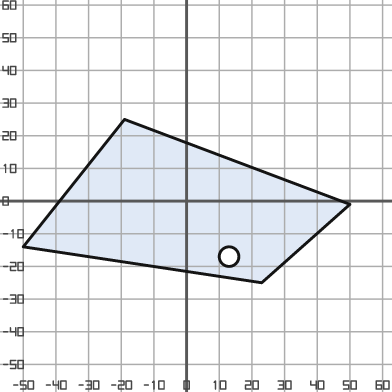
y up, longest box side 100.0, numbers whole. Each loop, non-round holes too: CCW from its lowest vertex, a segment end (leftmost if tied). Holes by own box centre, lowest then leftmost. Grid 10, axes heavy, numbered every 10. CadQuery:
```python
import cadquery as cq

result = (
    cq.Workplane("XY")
    .moveTo(23.0, -25.0)
    .lineTo(50.0, -1.0)
    .lineTo(-19.0, 25.0)
    .lineTo(-50.0, -14.0)
    .close()
    .moveTo(13.0, -17.0)
    .circle(3.0)
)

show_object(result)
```